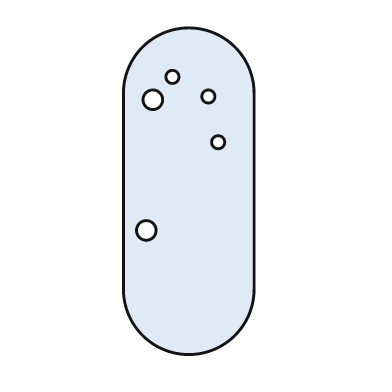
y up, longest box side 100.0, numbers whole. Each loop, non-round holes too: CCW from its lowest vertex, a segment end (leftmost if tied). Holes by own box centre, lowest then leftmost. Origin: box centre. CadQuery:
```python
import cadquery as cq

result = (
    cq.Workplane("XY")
    .moveTo(-20.0, -30.0)
    .threePointArc((0.0, -50.0), (20.0, -30.0))
    .lineTo(20.0, 30.0)
    .threePointArc((0.0, 50.0), (-20.0, 30.0))
    .close()
    .moveTo(-13.0, -12.0)
    .circle(3.0)
    .moveTo(9.0, 15.0)
    .circle(2.0)
    .moveTo(-11.0, 28.0)
    .circle(3.0)
    .moveTo(6.0, 29.0)
    .circle(2.0)
    .moveTo(-5.0, 35.0)
    .circle(2.0)
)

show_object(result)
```